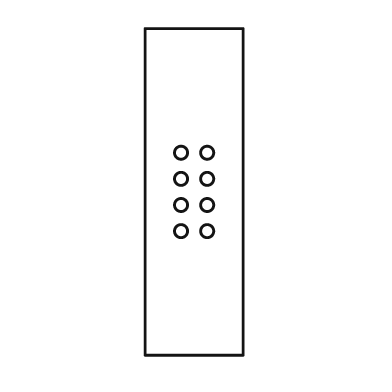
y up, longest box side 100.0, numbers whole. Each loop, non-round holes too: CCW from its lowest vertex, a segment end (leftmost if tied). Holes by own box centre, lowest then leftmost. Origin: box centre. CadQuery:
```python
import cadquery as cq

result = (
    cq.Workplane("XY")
    .moveTo(-15.0, -50.0)
    .lineTo(15.0, -50.0)
    .lineTo(15.0, 50.0)
    .lineTo(-15.0, 50.0)
    .close()
    .moveTo(-4.0, -12.0)
    .circle(2.0)
    .moveTo(4.0, -12.0)
    .circle(2.0)
    .moveTo(-4.0, -4.0)
    .circle(2.0)
    .moveTo(4.0, -4.0)
    .circle(2.0)
    .moveTo(-4.0, 4.0)
    .circle(2.0)
    .moveTo(4.0, 4.0)
    .circle(2.0)
    .moveTo(-4.0, 12.0)
    .circle(2.0)
    .moveTo(4.0, 12.0)
    .circle(2.0)
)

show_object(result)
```